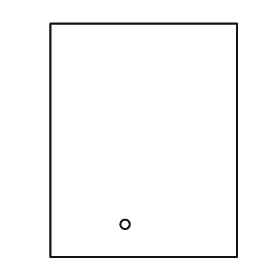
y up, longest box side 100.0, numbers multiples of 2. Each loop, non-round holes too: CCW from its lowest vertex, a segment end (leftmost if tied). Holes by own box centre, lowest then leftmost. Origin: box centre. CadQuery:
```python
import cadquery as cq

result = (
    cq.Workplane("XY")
    .moveTo(-40.0, -50.0)
    .lineTo(40.0, -50.0)
    .lineTo(40.0, 50.0)
    .lineTo(-40.0, 50.0)
    .close()
    .moveTo(-8.0, -36.0)
    .circle(2.0)
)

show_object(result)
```